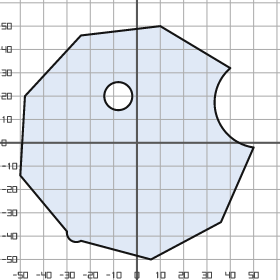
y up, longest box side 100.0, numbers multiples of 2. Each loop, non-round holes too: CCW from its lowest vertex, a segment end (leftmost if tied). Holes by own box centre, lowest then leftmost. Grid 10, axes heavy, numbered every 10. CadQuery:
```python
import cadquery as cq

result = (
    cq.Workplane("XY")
    .moveTo(6.0, -50.0)
    .lineTo(36.0, -34.0)
    .lineTo(50.0, -2.0)
    .threePointArc((34.0, 12.0), (40.0, 32.0))
    .lineTo(10.0, 50.0)
    .lineTo(-24.0, 46.0)
    .lineTo(-48.0, 20.0)
    .lineTo(-50.0, -14.0)
    .lineTo(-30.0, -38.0)
    .threePointArc((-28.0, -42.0), (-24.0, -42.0))
    .close()
    .moveTo(-8.0, 20.0)
    .circle(6.0)
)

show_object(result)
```